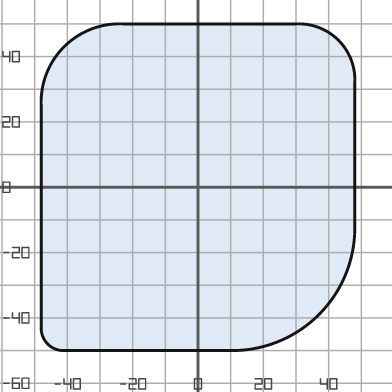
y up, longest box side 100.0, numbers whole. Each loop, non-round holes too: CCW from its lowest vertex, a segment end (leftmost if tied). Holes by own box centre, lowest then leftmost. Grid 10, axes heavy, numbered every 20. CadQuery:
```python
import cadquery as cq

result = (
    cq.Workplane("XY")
    .moveTo(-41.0, -50.0)
    .lineTo(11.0, -50.0)
    .threePointArc((37.0, -39.0), (48.0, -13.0))
    .lineTo(48.0, 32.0)
    .threePointArc((43.0, 45.0), (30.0, 50.0))
    .lineTo(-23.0, 50.0)
    .threePointArc((-41.0, 43.0), (-48.0, 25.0))
    .lineTo(-48.0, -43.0)
    .threePointArc((-46.0, -48.0), (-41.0, -50.0))
    .close()
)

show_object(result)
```